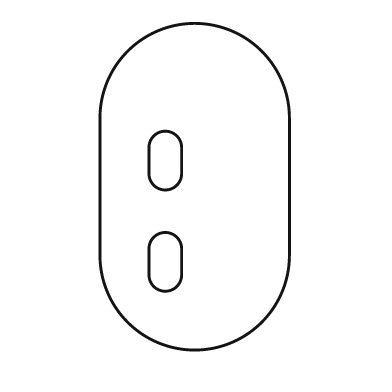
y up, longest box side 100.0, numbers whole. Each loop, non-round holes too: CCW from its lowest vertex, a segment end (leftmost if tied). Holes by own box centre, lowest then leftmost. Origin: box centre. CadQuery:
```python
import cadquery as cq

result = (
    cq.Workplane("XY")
    .moveTo(-29.0, -21.0)
    .threePointArc((0.0, -50.0), (29.0, -21.0))
    .lineTo(29.0, 21.0)
    .threePointArc((0.0, 50.0), (-29.0, 21.0))
    .close()
    .moveTo(-14.0, -27.0)
    .threePointArc((-9.0, -32.0), (-4.0, -27.0))
    .lineTo(-4.0, -19.0)
    .threePointArc((-9.0, -14.0), (-14.0, -19.0))
    .close()
    .moveTo(-14.0, 4.0)
    .threePointArc((-9.0, -1.0), (-4.0, 4.0))
    .lineTo(-4.0, 12.0)
    .threePointArc((-9.0, 17.0), (-14.0, 12.0))
    .close()
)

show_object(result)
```